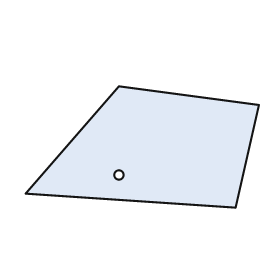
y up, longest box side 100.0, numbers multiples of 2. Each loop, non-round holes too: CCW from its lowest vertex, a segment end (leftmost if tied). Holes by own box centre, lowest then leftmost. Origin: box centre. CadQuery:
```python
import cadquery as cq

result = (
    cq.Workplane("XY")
    .moveTo(40.0, -26.0)
    .lineTo(50.0, 18.0)
    .lineTo(-10.0, 26.0)
    .lineTo(-50.0, -20.0)
    .close()
    .moveTo(-10.0, -12.0)
    .circle(2.0)
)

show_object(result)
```